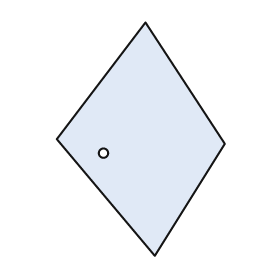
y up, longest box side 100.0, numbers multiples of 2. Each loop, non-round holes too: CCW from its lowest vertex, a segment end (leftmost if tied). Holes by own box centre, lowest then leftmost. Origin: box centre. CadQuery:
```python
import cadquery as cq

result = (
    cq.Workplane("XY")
    .moveTo(6.0, -50.0)
    .lineTo(36.0, -2.0)
    .lineTo(2.0, 50.0)
    .lineTo(-36.0, 0.0)
    .close()
    .moveTo(-16.0, -6.0)
    .circle(2.0)
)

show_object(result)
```